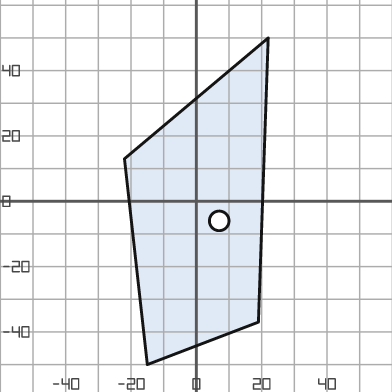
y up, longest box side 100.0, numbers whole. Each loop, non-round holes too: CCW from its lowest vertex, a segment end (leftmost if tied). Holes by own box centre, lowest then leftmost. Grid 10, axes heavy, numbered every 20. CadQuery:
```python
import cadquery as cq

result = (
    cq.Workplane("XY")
    .moveTo(-15.0, -50.0)
    .lineTo(19.0, -37.0)
    .lineTo(22.0, 50.0)
    .lineTo(-22.0, 13.0)
    .close()
    .moveTo(7.0, -6.0)
    .circle(3.0)
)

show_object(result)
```